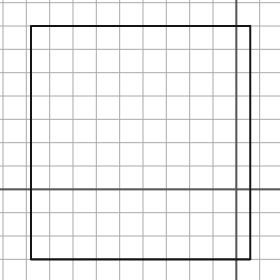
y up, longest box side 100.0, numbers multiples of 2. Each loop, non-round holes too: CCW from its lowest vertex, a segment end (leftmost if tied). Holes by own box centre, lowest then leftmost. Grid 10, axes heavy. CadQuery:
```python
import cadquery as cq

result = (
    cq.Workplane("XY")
    .moveTo(-88.0, -30.0)
    .lineTo(6.0, -30.0)
    .lineTo(6.0, 70.0)
    .lineTo(-88.0, 70.0)
    .close()
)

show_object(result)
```